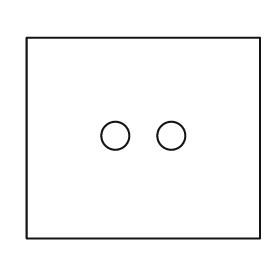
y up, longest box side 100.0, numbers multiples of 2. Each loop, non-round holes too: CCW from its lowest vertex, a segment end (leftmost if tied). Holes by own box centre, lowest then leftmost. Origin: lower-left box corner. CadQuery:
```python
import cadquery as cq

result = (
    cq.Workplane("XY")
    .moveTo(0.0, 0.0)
    .lineTo(100.0, 0.0)
    .lineTo(100.0, 86.0)
    .lineTo(0.0, 86.0)
    .close()
    .moveTo(38.0, 44.0)
    .circle(6.0)
    .moveTo(62.0, 44.0)
    .circle(6.0)
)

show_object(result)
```